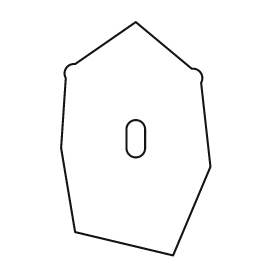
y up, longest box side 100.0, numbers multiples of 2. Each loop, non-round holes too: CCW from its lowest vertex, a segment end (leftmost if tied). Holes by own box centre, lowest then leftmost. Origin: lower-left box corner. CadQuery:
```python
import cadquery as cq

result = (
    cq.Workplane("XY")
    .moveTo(48.0, 0.0)
    .lineTo(64.0, 38.0)
    .lineTo(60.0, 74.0)
    .threePointArc((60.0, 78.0), (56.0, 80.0))
    .lineTo(32.0, 100.0)
    .lineTo(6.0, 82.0)
    .threePointArc((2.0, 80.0), (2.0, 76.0))
    .lineTo(0.0, 46.0)
    .lineTo(6.0, 10.0)
    .close()
    .moveTo(28.0, 46.0)
    .threePointArc((32.0, 42.0), (36.0, 46.0))
    .lineTo(36.0, 54.0)
    .threePointArc((32.0, 58.0), (28.0, 54.0))
    .close()
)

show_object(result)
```